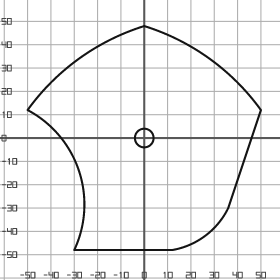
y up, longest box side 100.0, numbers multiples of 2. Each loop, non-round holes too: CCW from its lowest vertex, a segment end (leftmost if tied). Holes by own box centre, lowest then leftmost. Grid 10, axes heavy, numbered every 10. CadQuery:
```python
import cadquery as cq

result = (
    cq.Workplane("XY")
    .moveTo(-30.0, -48.0)
    .lineTo(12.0, -48.0)
    .threePointArc((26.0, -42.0), (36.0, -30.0))
    .lineTo(50.0, 12.0)
    .threePointArc((28.0, 34.0), (0.0, 48.0))
    .threePointArc((-28.0, 34.0), (-50.0, 12.0))
    .threePointArc((-28.0, -14.0), (-30.0, -48.0))
    .close()
    .moveTo(0.0, 0.0)
    .circle(4.0)
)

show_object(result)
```